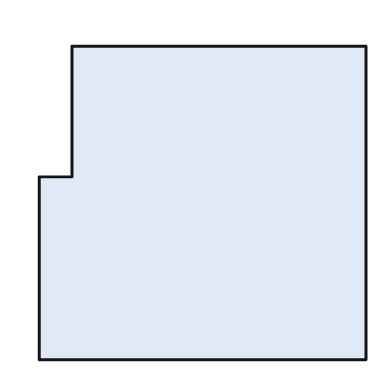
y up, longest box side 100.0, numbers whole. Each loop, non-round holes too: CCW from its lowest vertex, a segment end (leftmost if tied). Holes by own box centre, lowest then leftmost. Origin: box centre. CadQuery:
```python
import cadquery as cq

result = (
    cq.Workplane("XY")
    .moveTo(-50.0, -48.0)
    .lineTo(50.0, -48.0)
    .lineTo(50.0, 48.0)
    .lineTo(-40.0, 48.0)
    .lineTo(-40.0, 8.0)
    .lineTo(-50.0, 8.0)
    .close()
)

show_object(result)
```